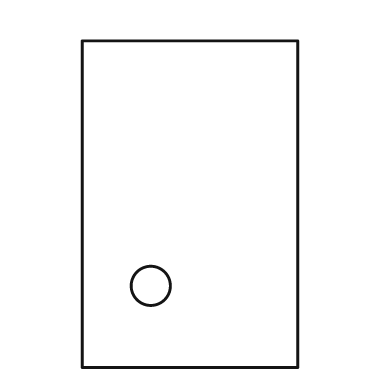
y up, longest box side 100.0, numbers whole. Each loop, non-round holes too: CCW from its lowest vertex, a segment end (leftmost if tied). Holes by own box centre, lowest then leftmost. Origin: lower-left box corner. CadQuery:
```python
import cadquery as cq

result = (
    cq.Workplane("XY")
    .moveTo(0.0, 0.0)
    .lineTo(66.0, 0.0)
    .lineTo(66.0, 100.0)
    .lineTo(0.0, 100.0)
    .close()
    .moveTo(21.0, 25.0)
    .circle(6.0)
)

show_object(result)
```